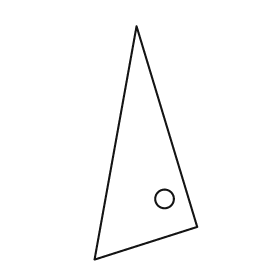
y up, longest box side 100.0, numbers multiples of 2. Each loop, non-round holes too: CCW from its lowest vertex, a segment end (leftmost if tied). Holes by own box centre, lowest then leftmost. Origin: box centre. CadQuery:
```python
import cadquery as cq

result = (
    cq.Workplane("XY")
    .moveTo(-22.0, -50.0)
    .lineTo(22.0, -36.0)
    .lineTo(-4.0, 50.0)
    .close()
    .moveTo(8.0, -24.0)
    .circle(4.0)
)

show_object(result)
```